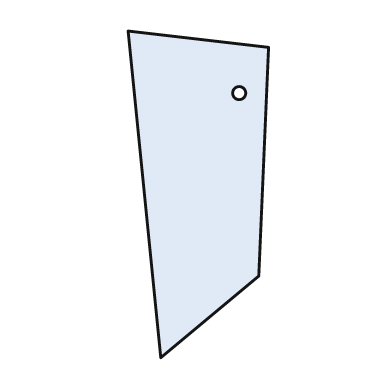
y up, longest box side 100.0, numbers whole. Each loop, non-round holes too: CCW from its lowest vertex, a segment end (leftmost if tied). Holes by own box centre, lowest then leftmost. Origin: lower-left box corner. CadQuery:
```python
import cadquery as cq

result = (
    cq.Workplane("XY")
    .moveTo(10.0, 0.0)
    .lineTo(40.0, 25.0)
    .lineTo(43.0, 95.0)
    .lineTo(0.0, 100.0)
    .close()
    .moveTo(34.0, 81.0)
    .circle(2.0)
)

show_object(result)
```